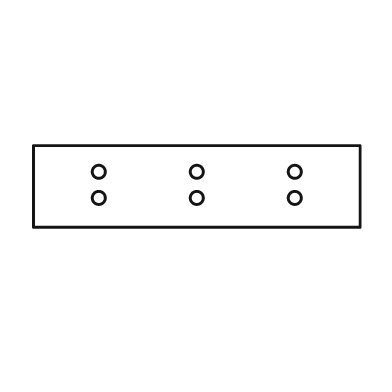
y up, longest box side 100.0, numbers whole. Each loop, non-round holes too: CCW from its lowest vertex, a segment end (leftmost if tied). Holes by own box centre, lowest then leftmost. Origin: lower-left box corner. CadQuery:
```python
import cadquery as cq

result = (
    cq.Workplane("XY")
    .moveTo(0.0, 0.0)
    .lineTo(100.0, 0.0)
    .lineTo(100.0, 25.0)
    .lineTo(0.0, 25.0)
    .close()
    .moveTo(20.0, 9.0)
    .circle(2.0)
    .moveTo(50.0, 9.0)
    .circle(2.0)
    .moveTo(80.0, 9.0)
    .circle(2.0)
    .moveTo(20.0, 17.0)
    .circle(2.0)
    .moveTo(50.0, 17.0)
    .circle(2.0)
    .moveTo(80.0, 17.0)
    .circle(2.0)
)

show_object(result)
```